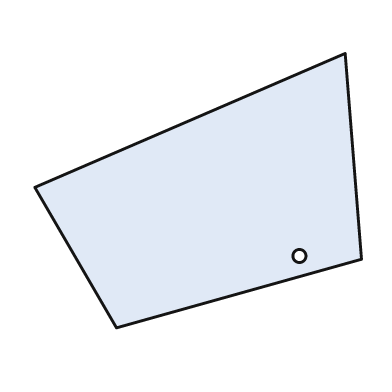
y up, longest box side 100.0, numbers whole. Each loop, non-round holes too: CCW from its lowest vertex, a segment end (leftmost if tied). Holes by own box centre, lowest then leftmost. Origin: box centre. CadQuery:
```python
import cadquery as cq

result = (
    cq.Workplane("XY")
    .moveTo(-25.0, -42.0)
    .lineTo(50.0, -21.0)
    .lineTo(45.0, 42.0)
    .lineTo(-50.0, 1.0)
    .close()
    .moveTo(31.0, -20.0)
    .circle(2.0)
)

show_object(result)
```